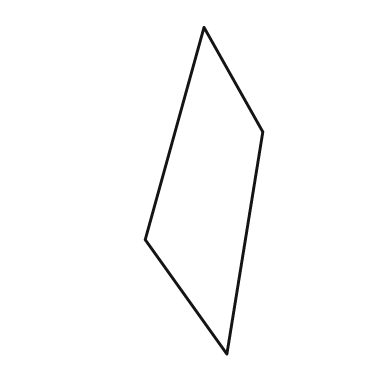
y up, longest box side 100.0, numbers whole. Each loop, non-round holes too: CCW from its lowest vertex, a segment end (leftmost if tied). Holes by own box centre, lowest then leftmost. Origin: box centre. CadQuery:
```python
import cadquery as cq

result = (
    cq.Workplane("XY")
    .moveTo(7.0, -50.0)
    .lineTo(18.0, 18.0)
    .lineTo(0.0, 50.0)
    .lineTo(-18.0, -15.0)
    .close()
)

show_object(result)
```